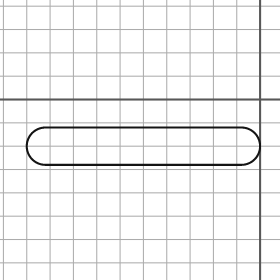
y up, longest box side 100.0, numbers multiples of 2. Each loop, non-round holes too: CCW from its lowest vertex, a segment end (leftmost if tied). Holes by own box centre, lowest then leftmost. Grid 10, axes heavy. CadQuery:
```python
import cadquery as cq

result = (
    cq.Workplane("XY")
    .moveTo(-92.0, -28.0)
    .lineTo(-8.0, -28.0)
    .threePointArc((0.0, -20.0), (-8.0, -12.0))
    .lineTo(-92.0, -12.0)
    .threePointArc((-100.0, -20.0), (-92.0, -28.0))
    .close()
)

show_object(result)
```